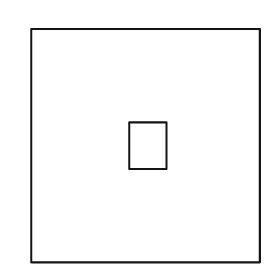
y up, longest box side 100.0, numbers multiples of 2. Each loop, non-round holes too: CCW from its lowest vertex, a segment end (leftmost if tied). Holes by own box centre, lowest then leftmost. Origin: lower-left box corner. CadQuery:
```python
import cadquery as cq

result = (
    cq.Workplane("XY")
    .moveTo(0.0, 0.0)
    .lineTo(98.0, 0.0)
    .lineTo(98.0, 100.0)
    .lineTo(0.0, 100.0)
    .close()
    .moveTo(42.0, 40.0)
    .lineTo(58.0, 40.0)
    .lineTo(58.0, 60.0)
    .lineTo(42.0, 60.0)
    .close()
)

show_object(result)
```